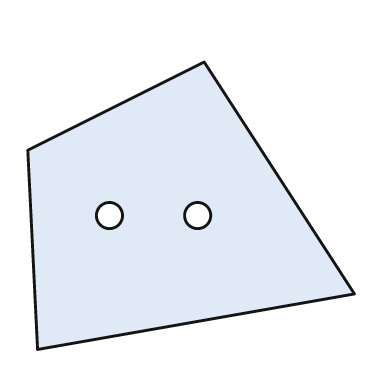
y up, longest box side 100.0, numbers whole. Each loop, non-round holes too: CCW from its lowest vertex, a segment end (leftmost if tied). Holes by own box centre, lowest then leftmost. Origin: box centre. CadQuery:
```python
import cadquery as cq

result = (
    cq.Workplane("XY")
    .moveTo(-47.0, -44.0)
    .lineTo(50.0, -27.0)
    .lineTo(4.0, 44.0)
    .lineTo(-50.0, 17.0)
    .close()
    .moveTo(-25.0, -3.0)
    .circle(4.0)
    .moveTo(2.0, -3.0)
    .circle(4.0)
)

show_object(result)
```